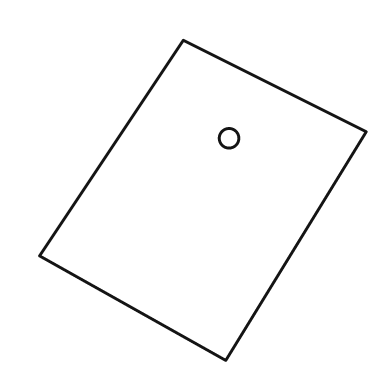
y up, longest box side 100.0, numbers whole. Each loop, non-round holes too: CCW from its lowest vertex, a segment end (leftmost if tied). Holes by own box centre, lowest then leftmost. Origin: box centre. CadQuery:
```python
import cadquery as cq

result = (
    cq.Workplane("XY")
    .moveTo(7.0, -49.0)
    .lineTo(50.0, 21.0)
    .lineTo(-6.0, 49.0)
    .lineTo(-50.0, -17.0)
    .close()
    .moveTo(8.0, 19.0)
    .circle(3.0)
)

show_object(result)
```